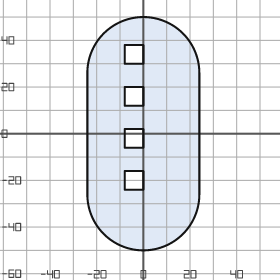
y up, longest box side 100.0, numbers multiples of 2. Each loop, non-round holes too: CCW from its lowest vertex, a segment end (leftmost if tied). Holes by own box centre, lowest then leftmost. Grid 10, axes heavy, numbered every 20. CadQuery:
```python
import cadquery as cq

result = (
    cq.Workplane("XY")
    .moveTo(-24.0, -26.0)
    .threePointArc((0.0, -50.0), (24.0, -26.0))
    .lineTo(24.0, 26.0)
    .threePointArc((0.0, 50.0), (-24.0, 26.0))
    .close()
    .moveTo(-8.0, -24.0)
    .lineTo(0.0, -24.0)
    .lineTo(0.0, -16.0)
    .lineTo(-8.0, -16.0)
    .close()
    .moveTo(-8.0, -6.0)
    .lineTo(0.0, -6.0)
    .lineTo(0.0, 2.0)
    .lineTo(-8.0, 2.0)
    .close()
    .moveTo(-8.0, 12.0)
    .lineTo(0.0, 12.0)
    .lineTo(0.0, 20.0)
    .lineTo(-8.0, 20.0)
    .close()
    .moveTo(-8.0, 30.0)
    .lineTo(0.0, 30.0)
    .lineTo(0.0, 38.0)
    .lineTo(-8.0, 38.0)
    .close()
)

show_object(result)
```